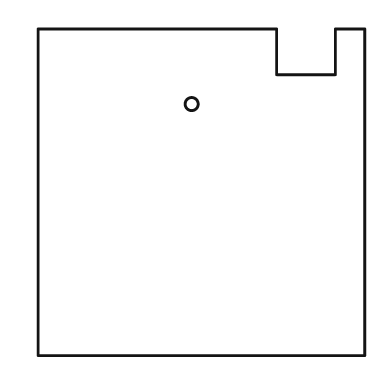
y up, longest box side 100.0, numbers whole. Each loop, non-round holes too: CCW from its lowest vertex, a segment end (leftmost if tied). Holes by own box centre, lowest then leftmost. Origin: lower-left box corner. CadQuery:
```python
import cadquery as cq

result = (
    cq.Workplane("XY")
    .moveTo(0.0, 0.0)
    .lineTo(100.0, 0.0)
    .lineTo(100.0, 100.0)
    .lineTo(91.0, 100.0)
    .lineTo(91.0, 86.0)
    .lineTo(73.0, 86.0)
    .lineTo(73.0, 100.0)
    .lineTo(0.0, 100.0)
    .close()
    .moveTo(47.0, 77.0)
    .circle(2.0)
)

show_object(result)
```